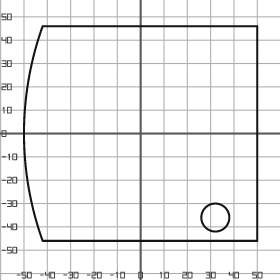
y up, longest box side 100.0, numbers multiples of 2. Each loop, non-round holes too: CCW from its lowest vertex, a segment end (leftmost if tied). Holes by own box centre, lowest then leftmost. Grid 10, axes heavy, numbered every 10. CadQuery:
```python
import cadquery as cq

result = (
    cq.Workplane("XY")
    .moveTo(-42.0, -46.0)
    .lineTo(50.0, -46.0)
    .lineTo(50.0, 46.0)
    .lineTo(-42.0, 46.0)
    .threePointArc((-50.0, 0.0), (-42.0, -46.0))
    .close()
    .moveTo(32.0, -36.0)
    .circle(6.0)
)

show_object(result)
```